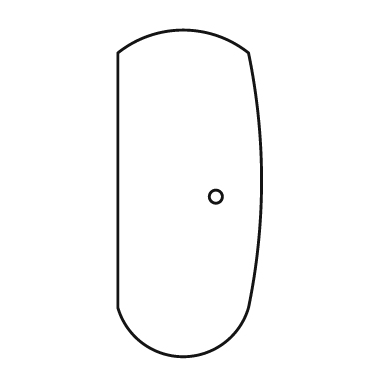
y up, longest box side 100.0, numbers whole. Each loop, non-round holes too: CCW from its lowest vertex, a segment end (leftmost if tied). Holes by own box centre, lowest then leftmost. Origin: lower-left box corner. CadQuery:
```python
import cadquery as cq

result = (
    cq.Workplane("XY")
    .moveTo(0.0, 15.0)
    .threePointArc((20.0, 0.0), (40.0, 15.0))
    .threePointArc((44.0, 54.0), (40.0, 93.0))
    .threePointArc((20.0, 100.0), (0.0, 93.0))
    .close()
    .moveTo(30.0, 49.0)
    .circle(2.0)
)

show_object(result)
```